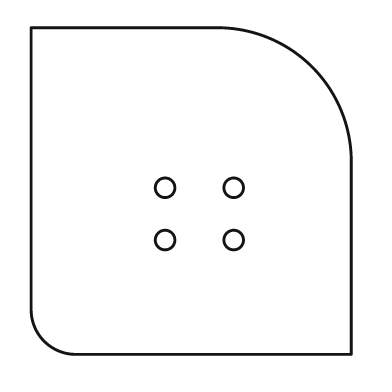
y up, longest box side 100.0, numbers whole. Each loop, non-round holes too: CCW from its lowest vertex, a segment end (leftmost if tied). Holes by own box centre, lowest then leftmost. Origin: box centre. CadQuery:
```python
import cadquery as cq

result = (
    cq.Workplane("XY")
    .moveTo(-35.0, -50.0)
    .lineTo(49.0, -50.0)
    .lineTo(49.0, 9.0)
    .threePointArc((37.0, 38.0), (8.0, 50.0))
    .lineTo(-49.0, 50.0)
    .lineTo(-49.0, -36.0)
    .threePointArc((-45.0, -46.0), (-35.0, -50.0))
    .close()
    .moveTo(-8.0, -15.0)
    .circle(3.0)
    .moveTo(13.0, -15.0)
    .circle(3.0)
    .moveTo(-8.0, 1.0)
    .circle(3.0)
    .moveTo(13.0, 1.0)
    .circle(3.0)
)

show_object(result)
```